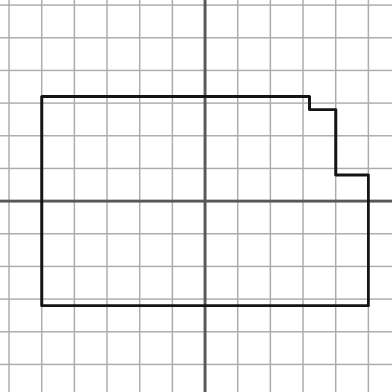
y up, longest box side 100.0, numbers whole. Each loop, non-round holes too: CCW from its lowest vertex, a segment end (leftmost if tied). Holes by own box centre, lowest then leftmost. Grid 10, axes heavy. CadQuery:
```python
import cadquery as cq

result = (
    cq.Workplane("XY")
    .moveTo(-50.0, -32.0)
    .lineTo(50.0, -32.0)
    .lineTo(50.0, 8.0)
    .lineTo(40.0, 8.0)
    .lineTo(40.0, 28.0)
    .lineTo(32.0, 28.0)
    .lineTo(32.0, 32.0)
    .lineTo(-50.0, 32.0)
    .close()
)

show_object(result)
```